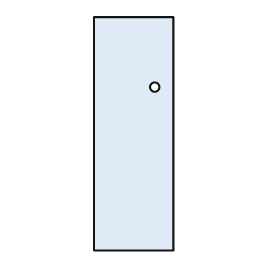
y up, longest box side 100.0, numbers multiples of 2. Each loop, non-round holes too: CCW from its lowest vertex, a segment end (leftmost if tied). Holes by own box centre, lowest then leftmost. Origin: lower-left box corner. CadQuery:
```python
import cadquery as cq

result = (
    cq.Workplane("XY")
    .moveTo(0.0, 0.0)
    .lineTo(34.0, 0.0)
    .lineTo(34.0, 100.0)
    .lineTo(0.0, 100.0)
    .close()
    .moveTo(26.0, 70.0)
    .circle(2.0)
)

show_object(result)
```